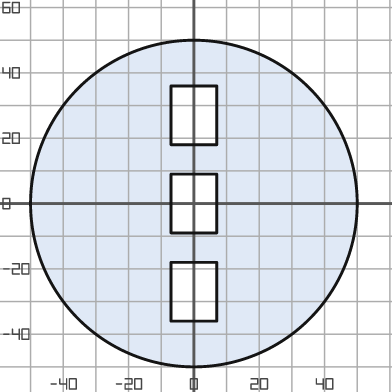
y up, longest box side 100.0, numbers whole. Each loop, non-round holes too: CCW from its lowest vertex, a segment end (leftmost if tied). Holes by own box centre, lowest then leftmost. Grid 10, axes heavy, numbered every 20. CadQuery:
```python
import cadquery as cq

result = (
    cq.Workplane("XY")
    .moveTo(0.0, 0.0)
    .circle(50.0)
    .moveTo(-7.0, -36.0)
    .lineTo(7.0, -36.0)
    .lineTo(7.0, -18.0)
    .lineTo(-7.0, -18.0)
    .close()
    .moveTo(-7.0, -9.0)
    .lineTo(7.0, -9.0)
    .lineTo(7.0, 9.0)
    .lineTo(-7.0, 9.0)
    .close()
    .moveTo(-7.0, 18.0)
    .lineTo(7.0, 18.0)
    .lineTo(7.0, 36.0)
    .lineTo(-7.0, 36.0)
    .close()
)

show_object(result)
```